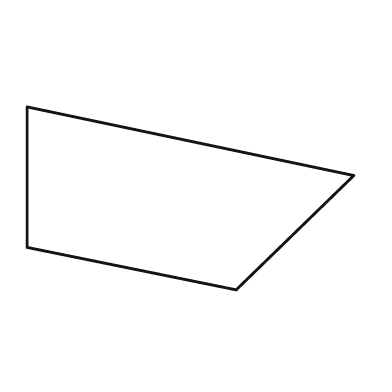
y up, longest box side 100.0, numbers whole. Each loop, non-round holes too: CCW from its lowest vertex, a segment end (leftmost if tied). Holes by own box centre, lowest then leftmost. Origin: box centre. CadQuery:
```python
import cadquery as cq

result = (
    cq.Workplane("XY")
    .moveTo(14.0, -28.0)
    .lineTo(50.0, 7.0)
    .lineTo(-50.0, 28.0)
    .lineTo(-50.0, -15.0)
    .close()
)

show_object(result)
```